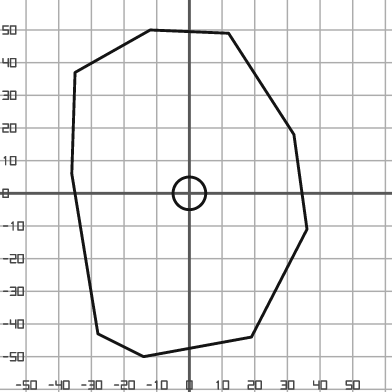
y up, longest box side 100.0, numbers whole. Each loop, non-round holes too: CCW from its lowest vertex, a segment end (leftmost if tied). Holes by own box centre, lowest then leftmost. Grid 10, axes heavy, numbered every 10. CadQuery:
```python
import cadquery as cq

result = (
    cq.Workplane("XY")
    .moveTo(-14.0, -50.0)
    .lineTo(19.0, -44.0)
    .lineTo(36.0, -11.0)
    .lineTo(32.0, 18.0)
    .lineTo(12.0, 49.0)
    .lineTo(-12.0, 50.0)
    .lineTo(-35.0, 37.0)
    .lineTo(-36.0, 6.0)
    .lineTo(-28.0, -43.0)
    .close()
    .moveTo(0.0, 0.0)
    .circle(5.0)
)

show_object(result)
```